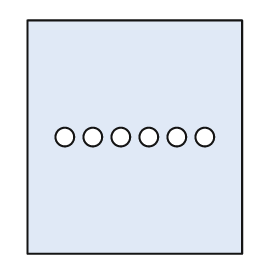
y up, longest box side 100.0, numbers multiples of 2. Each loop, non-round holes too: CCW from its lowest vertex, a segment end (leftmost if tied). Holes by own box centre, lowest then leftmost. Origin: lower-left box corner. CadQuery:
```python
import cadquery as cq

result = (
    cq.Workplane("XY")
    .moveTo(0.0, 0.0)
    .lineTo(92.0, 0.0)
    .lineTo(92.0, 100.0)
    .lineTo(0.0, 100.0)
    .close()
    .moveTo(16.0, 50.0)
    .circle(4.0)
    .moveTo(28.0, 50.0)
    .circle(4.0)
    .moveTo(40.0, 50.0)
    .circle(4.0)
    .moveTo(52.0, 50.0)
    .circle(4.0)
    .moveTo(64.0, 50.0)
    .circle(4.0)
    .moveTo(76.0, 50.0)
    .circle(4.0)
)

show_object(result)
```